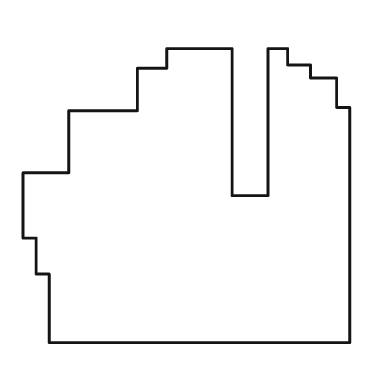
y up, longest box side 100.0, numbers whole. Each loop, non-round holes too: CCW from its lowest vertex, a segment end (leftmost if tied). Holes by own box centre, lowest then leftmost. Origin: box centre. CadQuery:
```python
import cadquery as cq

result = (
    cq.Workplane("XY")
    .moveTo(-42.0, -45.0)
    .lineTo(50.0, -45.0)
    .lineTo(50.0, 27.0)
    .lineTo(46.0, 27.0)
    .lineTo(46.0, 36.0)
    .lineTo(38.0, 36.0)
    .lineTo(38.0, 40.0)
    .lineTo(31.0, 40.0)
    .lineTo(31.0, 45.0)
    .lineTo(25.0, 45.0)
    .lineTo(25.0, 0.0)
    .lineTo(14.0, 0.0)
    .lineTo(14.0, 45.0)
    .lineTo(-6.0, 45.0)
    .lineTo(-6.0, 39.0)
    .lineTo(-15.0, 39.0)
    .lineTo(-15.0, 26.0)
    .lineTo(-36.0, 26.0)
    .lineTo(-36.0, 7.0)
    .lineTo(-50.0, 7.0)
    .lineTo(-50.0, -13.0)
    .lineTo(-46.0, -13.0)
    .lineTo(-46.0, -24.0)
    .lineTo(-42.0, -24.0)
    .close()
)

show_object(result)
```